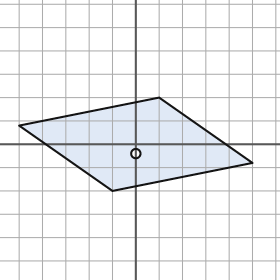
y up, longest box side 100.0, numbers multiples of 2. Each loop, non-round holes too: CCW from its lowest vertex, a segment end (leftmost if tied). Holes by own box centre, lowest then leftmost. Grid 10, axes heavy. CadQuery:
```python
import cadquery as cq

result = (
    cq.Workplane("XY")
    .moveTo(-10.0, -20.0)
    .lineTo(50.0, -8.0)
    .lineTo(10.0, 20.0)
    .lineTo(-50.0, 8.0)
    .close()
    .moveTo(0.0, -4.0)
    .circle(2.0)
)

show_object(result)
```